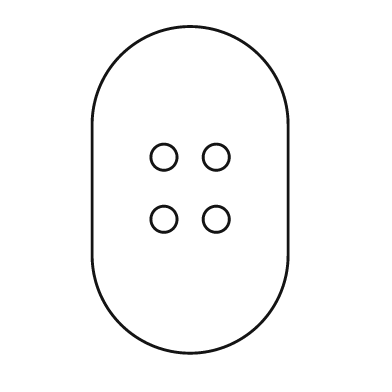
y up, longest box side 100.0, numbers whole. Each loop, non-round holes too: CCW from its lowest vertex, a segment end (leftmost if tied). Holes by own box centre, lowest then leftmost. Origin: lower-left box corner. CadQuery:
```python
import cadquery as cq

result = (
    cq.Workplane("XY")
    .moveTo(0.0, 30.0)
    .threePointArc((30.0, 0.0), (60.0, 30.0))
    .lineTo(60.0, 70.0)
    .threePointArc((30.0, 100.0), (0.0, 70.0))
    .close()
    .moveTo(22.0, 41.0)
    .circle(4.0)
    .moveTo(38.0, 41.0)
    .circle(4.0)
    .moveTo(22.0, 60.0)
    .circle(4.0)
    .moveTo(38.0, 60.0)
    .circle(4.0)
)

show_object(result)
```